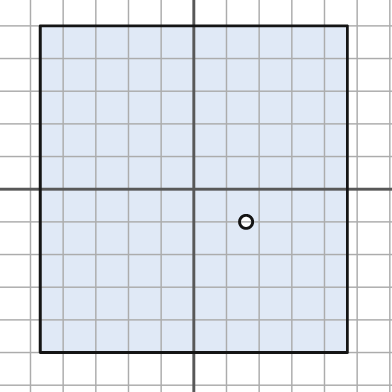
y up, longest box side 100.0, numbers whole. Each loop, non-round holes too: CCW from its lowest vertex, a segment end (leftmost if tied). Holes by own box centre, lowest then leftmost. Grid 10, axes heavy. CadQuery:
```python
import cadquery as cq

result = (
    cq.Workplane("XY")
    .moveTo(-47.0, -50.0)
    .lineTo(47.0, -50.0)
    .lineTo(47.0, 50.0)
    .lineTo(-47.0, 50.0)
    .close()
    .moveTo(16.0, -10.0)
    .circle(2.0)
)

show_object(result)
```